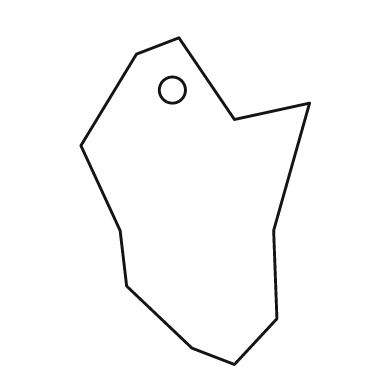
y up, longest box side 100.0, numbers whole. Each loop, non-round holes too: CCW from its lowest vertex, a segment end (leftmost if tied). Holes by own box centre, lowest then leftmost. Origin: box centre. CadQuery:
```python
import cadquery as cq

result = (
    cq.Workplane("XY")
    .moveTo(12.0, -50.0)
    .lineTo(25.0, -36.0)
    .lineTo(24.0, -9.0)
    .lineTo(35.0, 30.0)
    .lineTo(12.0, 25.0)
    .lineTo(-5.0, 50.0)
    .lineTo(-18.0, 45.0)
    .lineTo(-35.0, 17.0)
    .lineTo(-23.0, -9.0)
    .lineTo(-21.0, -26.0)
    .lineTo(-1.0, -45.0)
    .close()
    .moveTo(-7.0, 34.0)
    .circle(4.0)
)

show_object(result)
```